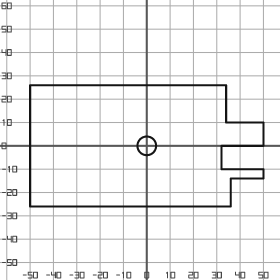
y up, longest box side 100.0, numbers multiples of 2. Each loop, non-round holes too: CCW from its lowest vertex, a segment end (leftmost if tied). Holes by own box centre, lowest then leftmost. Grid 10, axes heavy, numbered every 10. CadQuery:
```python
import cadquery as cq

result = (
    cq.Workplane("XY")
    .moveTo(-50.0, -26.0)
    .lineTo(36.0, -26.0)
    .lineTo(36.0, -14.0)
    .lineTo(50.0, -14.0)
    .lineTo(50.0, -10.0)
    .lineTo(32.0, -10.0)
    .lineTo(32.0, 0.0)
    .lineTo(50.0, 0.0)
    .lineTo(50.0, 10.0)
    .lineTo(34.0, 10.0)
    .lineTo(34.0, 26.0)
    .lineTo(-50.0, 26.0)
    .close()
    .moveTo(0.0, 0.0)
    .circle(4.0)
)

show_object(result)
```